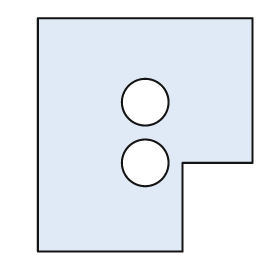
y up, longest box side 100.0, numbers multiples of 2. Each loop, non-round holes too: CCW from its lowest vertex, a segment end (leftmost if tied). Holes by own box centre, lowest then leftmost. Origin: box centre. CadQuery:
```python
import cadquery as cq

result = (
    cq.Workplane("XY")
    .moveTo(-46.0, -50.0)
    .lineTo(16.0, -50.0)
    .lineTo(16.0, -12.0)
    .lineTo(46.0, -12.0)
    .lineTo(46.0, 50.0)
    .lineTo(-46.0, 50.0)
    .close()
    .moveTo(0.0, -12.0)
    .circle(10.0)
    .moveTo(0.0, 14.0)
    .circle(10.0)
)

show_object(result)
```